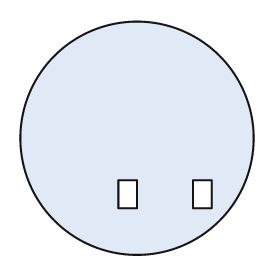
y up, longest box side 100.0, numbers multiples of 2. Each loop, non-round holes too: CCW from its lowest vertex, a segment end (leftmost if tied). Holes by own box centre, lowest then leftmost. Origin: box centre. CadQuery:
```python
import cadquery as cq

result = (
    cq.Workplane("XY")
    .moveTo(0.0, 0.0)
    .circle(50.0)
    .moveTo(-8.0, -30.0)
    .lineTo(0.0, -30.0)
    .lineTo(0.0, -18.0)
    .lineTo(-8.0, -18.0)
    .close()
    .moveTo(24.0, -30.0)
    .lineTo(32.0, -30.0)
    .lineTo(32.0, -18.0)
    .lineTo(24.0, -18.0)
    .close()
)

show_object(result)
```